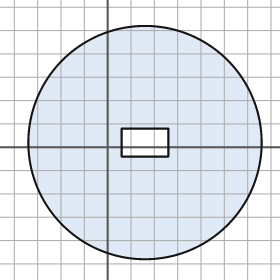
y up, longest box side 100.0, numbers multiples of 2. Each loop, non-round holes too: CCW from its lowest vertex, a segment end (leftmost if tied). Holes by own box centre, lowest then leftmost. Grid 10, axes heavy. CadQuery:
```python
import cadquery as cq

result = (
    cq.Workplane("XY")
    .moveTo(16.0, 2.0)
    .circle(50.0)
    .moveTo(6.0, -4.0)
    .lineTo(26.0, -4.0)
    .lineTo(26.0, 8.0)
    .lineTo(6.0, 8.0)
    .close()
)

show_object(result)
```